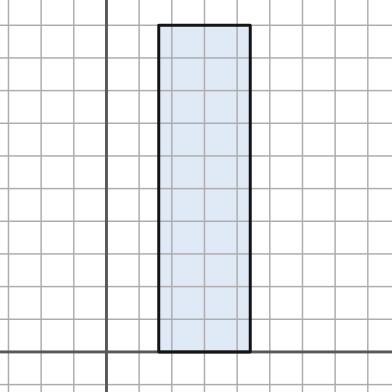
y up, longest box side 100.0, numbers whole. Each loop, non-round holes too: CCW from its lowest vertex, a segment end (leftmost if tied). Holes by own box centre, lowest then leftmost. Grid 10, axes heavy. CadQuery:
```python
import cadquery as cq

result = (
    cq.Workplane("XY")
    .moveTo(16.0, 0.0)
    .lineTo(44.0, 0.0)
    .lineTo(44.0, 100.0)
    .lineTo(16.0, 100.0)
    .close()
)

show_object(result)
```